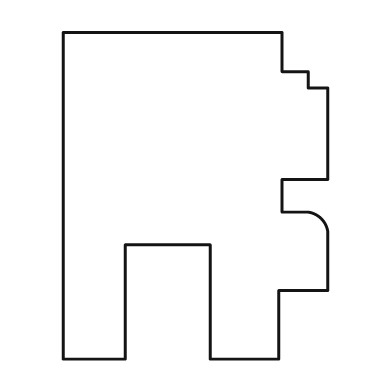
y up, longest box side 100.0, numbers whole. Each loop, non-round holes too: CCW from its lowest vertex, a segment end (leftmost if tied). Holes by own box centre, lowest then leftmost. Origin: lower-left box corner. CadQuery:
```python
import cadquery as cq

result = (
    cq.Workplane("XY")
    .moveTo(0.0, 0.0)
    .lineTo(19.0, 0.0)
    .lineTo(19.0, 35.0)
    .lineTo(45.0, 35.0)
    .lineTo(45.0, 0.0)
    .lineTo(66.0, 0.0)
    .lineTo(66.0, 21.0)
    .lineTo(81.0, 21.0)
    .lineTo(81.0, 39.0)
    .threePointArc((79.0, 43.0), (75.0, 45.0))
    .lineTo(67.0, 45.0)
    .lineTo(67.0, 55.0)
    .lineTo(81.0, 55.0)
    .lineTo(81.0, 83.0)
    .lineTo(75.0, 83.0)
    .lineTo(75.0, 88.0)
    .lineTo(67.0, 88.0)
    .lineTo(67.0, 100.0)
    .lineTo(0.0, 100.0)
    .close()
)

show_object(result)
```